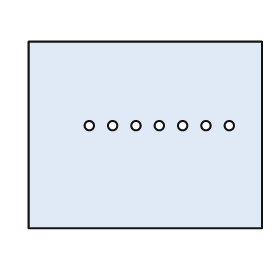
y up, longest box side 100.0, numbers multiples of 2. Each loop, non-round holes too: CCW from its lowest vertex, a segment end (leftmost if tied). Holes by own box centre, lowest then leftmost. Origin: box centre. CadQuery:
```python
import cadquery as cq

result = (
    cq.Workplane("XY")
    .moveTo(-50.0, -40.0)
    .lineTo(50.0, -40.0)
    .lineTo(50.0, 40.0)
    .lineTo(-50.0, 40.0)
    .close()
    .moveTo(-24.0, 4.0)
    .circle(2.0)
    .moveTo(-14.0, 4.0)
    .circle(2.0)
    .moveTo(-4.0, 4.0)
    .circle(2.0)
    .moveTo(6.0, 4.0)
    .circle(2.0)
    .moveTo(16.0, 4.0)
    .circle(2.0)
    .moveTo(26.0, 4.0)
    .circle(2.0)
    .moveTo(36.0, 4.0)
    .circle(2.0)
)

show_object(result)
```